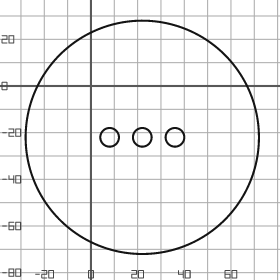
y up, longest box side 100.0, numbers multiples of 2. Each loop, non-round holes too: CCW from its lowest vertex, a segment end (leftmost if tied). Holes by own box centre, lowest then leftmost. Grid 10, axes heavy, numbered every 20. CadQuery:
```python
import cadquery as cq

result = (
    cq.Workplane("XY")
    .moveTo(22.0, -22.0)
    .circle(50.0)
    .moveTo(8.0, -22.0)
    .circle(4.0)
    .moveTo(22.0, -22.0)
    .circle(4.0)
    .moveTo(36.0, -22.0)
    .circle(4.0)
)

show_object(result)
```